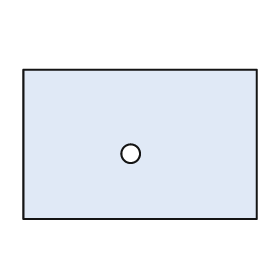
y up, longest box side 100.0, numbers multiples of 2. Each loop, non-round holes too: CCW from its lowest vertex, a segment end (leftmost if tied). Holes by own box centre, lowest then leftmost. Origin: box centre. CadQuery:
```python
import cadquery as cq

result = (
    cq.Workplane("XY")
    .moveTo(-50.0, -32.0)
    .lineTo(50.0, -32.0)
    .lineTo(50.0, 32.0)
    .lineTo(-50.0, 32.0)
    .close()
    .moveTo(-4.0, -4.0)
    .circle(4.0)
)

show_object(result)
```